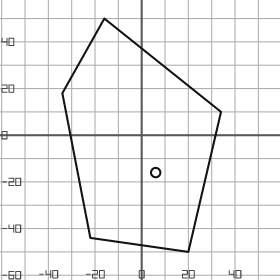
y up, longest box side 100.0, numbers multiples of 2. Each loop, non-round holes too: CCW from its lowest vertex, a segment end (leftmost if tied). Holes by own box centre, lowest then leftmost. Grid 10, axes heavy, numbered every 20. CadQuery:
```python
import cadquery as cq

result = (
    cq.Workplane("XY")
    .moveTo(20.0, -50.0)
    .lineTo(34.0, 10.0)
    .lineTo(-16.0, 50.0)
    .lineTo(-34.0, 18.0)
    .lineTo(-22.0, -44.0)
    .close()
    .moveTo(6.0, -16.0)
    .circle(2.0)
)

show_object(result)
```